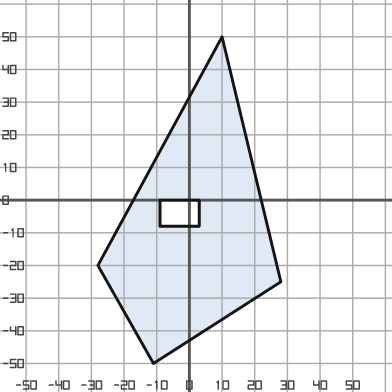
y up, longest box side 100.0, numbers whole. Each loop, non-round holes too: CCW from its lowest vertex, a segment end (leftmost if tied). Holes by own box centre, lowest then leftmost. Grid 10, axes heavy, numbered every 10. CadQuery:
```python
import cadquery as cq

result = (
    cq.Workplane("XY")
    .moveTo(-11.0, -50.0)
    .lineTo(28.0, -25.0)
    .lineTo(10.0, 50.0)
    .lineTo(-28.0, -20.0)
    .close()
    .moveTo(-9.0, -8.0)
    .lineTo(3.0, -8.0)
    .lineTo(3.0, 0.0)
    .lineTo(-9.0, 0.0)
    .close()
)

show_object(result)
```